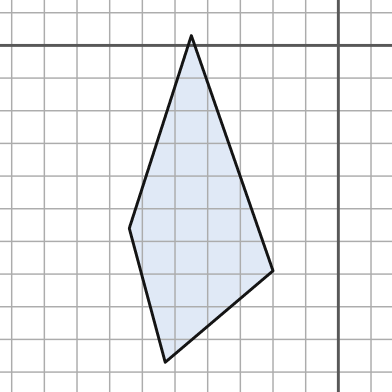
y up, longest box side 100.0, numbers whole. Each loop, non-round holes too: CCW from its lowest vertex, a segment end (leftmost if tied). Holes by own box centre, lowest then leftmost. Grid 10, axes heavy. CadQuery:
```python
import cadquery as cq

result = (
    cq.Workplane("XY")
    .moveTo(-53.0, -97.0)
    .lineTo(-20.0, -69.0)
    .lineTo(-45.0, 3.0)
    .lineTo(-64.0, -56.0)
    .close()
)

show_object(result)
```